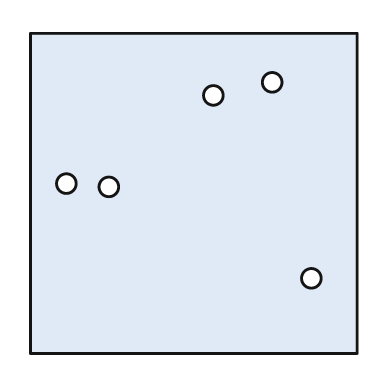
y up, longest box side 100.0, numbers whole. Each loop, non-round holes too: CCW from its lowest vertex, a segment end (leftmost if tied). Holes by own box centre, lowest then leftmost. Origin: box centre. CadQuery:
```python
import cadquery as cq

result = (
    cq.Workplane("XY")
    .moveTo(-50.0, -49.0)
    .lineTo(50.0, -49.0)
    .lineTo(50.0, 49.0)
    .lineTo(-50.0, 49.0)
    .close()
    .moveTo(36.0, -26.0)
    .circle(3.0)
    .moveTo(-26.0, 2.0)
    .circle(3.0)
    .moveTo(-39.0, 3.0)
    .circle(3.0)
    .moveTo(6.0, 30.0)
    .circle(3.0)
    .moveTo(24.0, 34.0)
    .circle(3.0)
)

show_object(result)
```